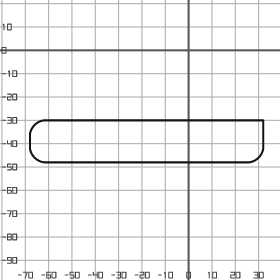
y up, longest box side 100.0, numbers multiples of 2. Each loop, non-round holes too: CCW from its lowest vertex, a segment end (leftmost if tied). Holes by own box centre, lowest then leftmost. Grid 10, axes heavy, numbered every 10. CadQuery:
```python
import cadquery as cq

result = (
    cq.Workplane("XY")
    .moveTo(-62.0, -48.0)
    .lineTo(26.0, -48.0)
    .threePointArc((30.0, -46.0), (32.0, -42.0))
    .lineTo(32.0, -30.0)
    .lineTo(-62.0, -30.0)
    .threePointArc((-66.0, -32.0), (-68.0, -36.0))
    .lineTo(-68.0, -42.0)
    .threePointArc((-66.0, -46.0), (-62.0, -48.0))
    .close()
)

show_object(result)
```